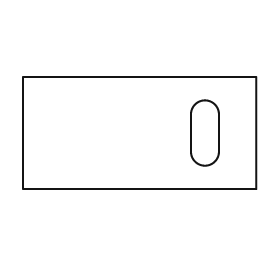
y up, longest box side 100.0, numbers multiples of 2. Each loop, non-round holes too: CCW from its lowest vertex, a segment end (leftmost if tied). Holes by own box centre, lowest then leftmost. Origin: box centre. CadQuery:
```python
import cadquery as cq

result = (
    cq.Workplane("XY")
    .moveTo(-50.0, -24.0)
    .lineTo(50.0, -24.0)
    .lineTo(50.0, 24.0)
    .lineTo(-50.0, 24.0)
    .close()
    .moveTo(22.0, -8.0)
    .threePointArc((28.0, -14.0), (34.0, -8.0))
    .lineTo(34.0, 8.0)
    .threePointArc((28.0, 14.0), (22.0, 8.0))
    .close()
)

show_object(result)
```